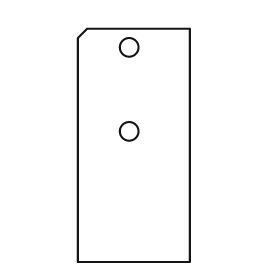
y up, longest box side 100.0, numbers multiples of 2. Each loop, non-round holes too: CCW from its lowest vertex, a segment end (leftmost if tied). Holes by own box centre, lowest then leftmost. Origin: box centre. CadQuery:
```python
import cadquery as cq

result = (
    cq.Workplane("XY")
    .moveTo(-24.0, -50.0)
    .lineTo(24.0, -50.0)
    .lineTo(24.0, 50.0)
    .lineTo(-20.0, 50.0)
    .lineTo(-24.0, 46.0)
    .close()
    .moveTo(-2.0, 6.0)
    .circle(4.0)
    .moveTo(-2.0, 42.0)
    .circle(4.0)
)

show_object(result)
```